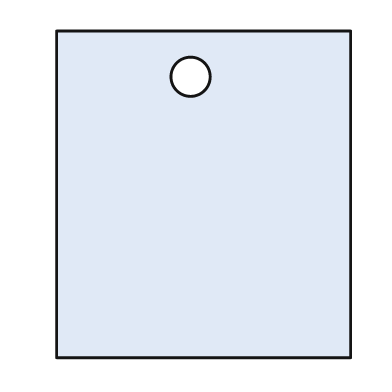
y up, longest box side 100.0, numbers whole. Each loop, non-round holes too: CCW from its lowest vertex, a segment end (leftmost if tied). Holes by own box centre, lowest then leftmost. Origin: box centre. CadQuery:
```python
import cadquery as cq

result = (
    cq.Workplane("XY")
    .moveTo(-45.0, -50.0)
    .lineTo(45.0, -50.0)
    .lineTo(45.0, 50.0)
    .lineTo(-45.0, 50.0)
    .close()
    .moveTo(-4.0, 36.0)
    .circle(6.0)
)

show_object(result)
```